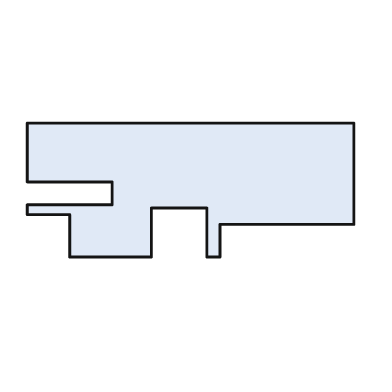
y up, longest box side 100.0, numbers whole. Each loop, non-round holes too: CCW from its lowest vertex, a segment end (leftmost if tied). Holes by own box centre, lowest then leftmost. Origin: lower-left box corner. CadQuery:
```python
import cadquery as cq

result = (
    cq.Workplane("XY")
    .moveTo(13.0, 0.0)
    .lineTo(38.0, 0.0)
    .lineTo(38.0, 15.0)
    .lineTo(55.0, 15.0)
    .lineTo(55.0, 0.0)
    .lineTo(59.0, 0.0)
    .lineTo(59.0, 10.0)
    .lineTo(100.0, 10.0)
    .lineTo(100.0, 41.0)
    .lineTo(0.0, 41.0)
    .lineTo(0.0, 23.0)
    .lineTo(26.0, 23.0)
    .lineTo(26.0, 16.0)
    .lineTo(0.0, 16.0)
    .lineTo(0.0, 13.0)
    .lineTo(13.0, 13.0)
    .close()
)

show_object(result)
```